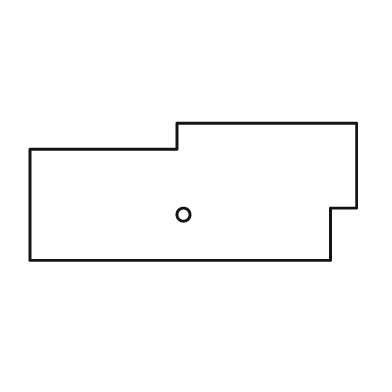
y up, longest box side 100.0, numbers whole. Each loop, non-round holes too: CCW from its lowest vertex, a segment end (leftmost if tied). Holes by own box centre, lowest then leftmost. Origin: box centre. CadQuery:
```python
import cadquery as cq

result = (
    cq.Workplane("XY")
    .moveTo(-50.0, -21.0)
    .lineTo(42.0, -21.0)
    .lineTo(42.0, -5.0)
    .lineTo(50.0, -5.0)
    .lineTo(50.0, 21.0)
    .lineTo(-5.0, 21.0)
    .lineTo(-5.0, 13.0)
    .lineTo(-50.0, 13.0)
    .close()
    .moveTo(-3.0, -7.0)
    .circle(2.0)
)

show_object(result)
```